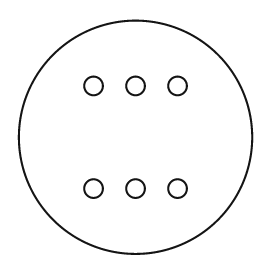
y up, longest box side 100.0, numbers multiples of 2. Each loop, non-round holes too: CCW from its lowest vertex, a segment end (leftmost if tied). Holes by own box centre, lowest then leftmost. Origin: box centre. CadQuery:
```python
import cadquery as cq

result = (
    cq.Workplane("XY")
    .moveTo(0.0, 0.0)
    .circle(50.0)
    .moveTo(-18.0, -22.0)
    .circle(4.0)
    .moveTo(0.0, -22.0)
    .circle(4.0)
    .moveTo(18.0, -22.0)
    .circle(4.0)
    .moveTo(-18.0, 22.0)
    .circle(4.0)
    .moveTo(0.0, 22.0)
    .circle(4.0)
    .moveTo(18.0, 22.0)
    .circle(4.0)
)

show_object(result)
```